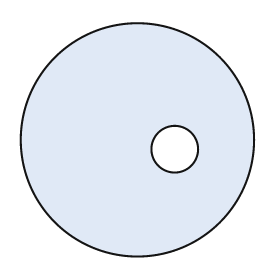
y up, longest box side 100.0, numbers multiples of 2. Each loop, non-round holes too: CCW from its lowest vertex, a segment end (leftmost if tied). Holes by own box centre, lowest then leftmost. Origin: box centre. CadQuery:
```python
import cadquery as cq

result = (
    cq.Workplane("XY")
    .moveTo(0.0, 0.0)
    .circle(50.0)
    .moveTo(16.0, -4.0)
    .circle(10.0)
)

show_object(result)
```